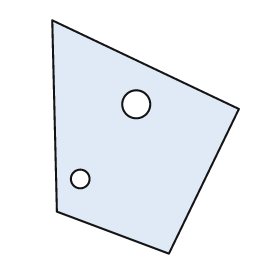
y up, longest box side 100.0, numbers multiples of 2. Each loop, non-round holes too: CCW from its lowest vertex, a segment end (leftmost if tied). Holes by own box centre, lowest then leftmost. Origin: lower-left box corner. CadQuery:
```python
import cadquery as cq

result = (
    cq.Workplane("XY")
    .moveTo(50.0, 0.0)
    .lineTo(80.0, 62.0)
    .lineTo(0.0, 100.0)
    .lineTo(2.0, 18.0)
    .close()
    .moveTo(12.0, 32.0)
    .circle(4.0)
    .moveTo(36.0, 64.0)
    .circle(6.0)
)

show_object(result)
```